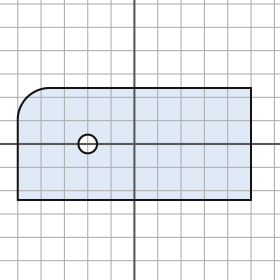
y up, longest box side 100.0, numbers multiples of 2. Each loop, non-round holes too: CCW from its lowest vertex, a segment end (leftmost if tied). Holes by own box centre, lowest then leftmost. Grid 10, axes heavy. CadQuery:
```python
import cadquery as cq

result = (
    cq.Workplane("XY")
    .moveTo(-50.0, -24.0)
    .lineTo(50.0, -24.0)
    .lineTo(50.0, 24.0)
    .lineTo(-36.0, 24.0)
    .threePointArc((-46.0, 20.0), (-50.0, 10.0))
    .close()
    .moveTo(-20.0, 0.0)
    .circle(4.0)
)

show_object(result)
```